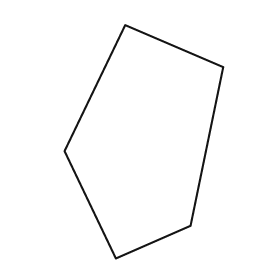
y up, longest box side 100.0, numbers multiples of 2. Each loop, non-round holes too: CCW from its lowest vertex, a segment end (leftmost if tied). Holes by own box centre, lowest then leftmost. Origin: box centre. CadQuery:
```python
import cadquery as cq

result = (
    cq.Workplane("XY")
    .moveTo(-12.0, -50.0)
    .lineTo(20.0, -36.0)
    .lineTo(34.0, 32.0)
    .lineTo(-8.0, 50.0)
    .lineTo(-34.0, -4.0)
    .close()
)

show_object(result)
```